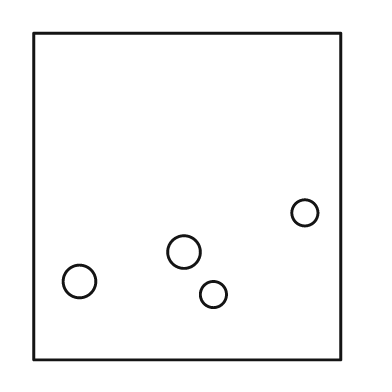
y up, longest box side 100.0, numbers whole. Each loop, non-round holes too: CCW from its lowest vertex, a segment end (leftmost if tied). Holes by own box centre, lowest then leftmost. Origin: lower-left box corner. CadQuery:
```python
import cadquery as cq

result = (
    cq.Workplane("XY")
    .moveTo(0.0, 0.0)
    .lineTo(94.0, 0.0)
    .lineTo(94.0, 100.0)
    .lineTo(0.0, 100.0)
    .close()
    .moveTo(55.0, 20.0)
    .circle(4.0)
    .moveTo(14.0, 24.0)
    .circle(5.0)
    .moveTo(46.0, 33.0)
    .circle(5.0)
    .moveTo(83.0, 45.0)
    .circle(4.0)
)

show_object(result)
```